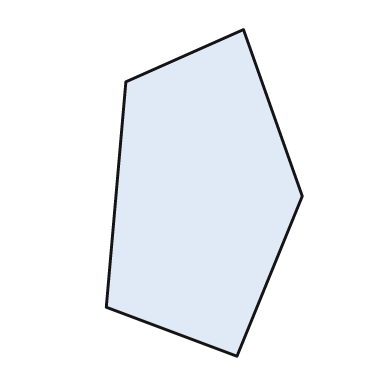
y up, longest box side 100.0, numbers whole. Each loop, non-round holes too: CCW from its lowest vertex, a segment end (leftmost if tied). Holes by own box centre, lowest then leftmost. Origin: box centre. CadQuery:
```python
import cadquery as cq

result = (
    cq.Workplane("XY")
    .moveTo(10.0, -50.0)
    .lineTo(30.0, -1.0)
    .lineTo(12.0, 50.0)
    .lineTo(-24.0, 34.0)
    .lineTo(-30.0, -35.0)
    .close()
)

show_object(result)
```